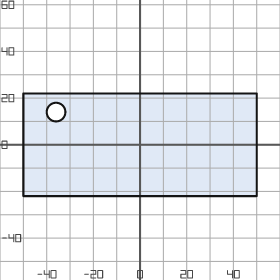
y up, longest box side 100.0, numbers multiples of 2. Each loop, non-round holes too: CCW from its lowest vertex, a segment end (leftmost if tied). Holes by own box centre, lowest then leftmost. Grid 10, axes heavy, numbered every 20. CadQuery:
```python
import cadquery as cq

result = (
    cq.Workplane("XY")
    .moveTo(-50.0, -22.0)
    .lineTo(50.0, -22.0)
    .lineTo(50.0, 22.0)
    .lineTo(-50.0, 22.0)
    .close()
    .moveTo(-36.0, 14.0)
    .circle(4.0)
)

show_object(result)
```